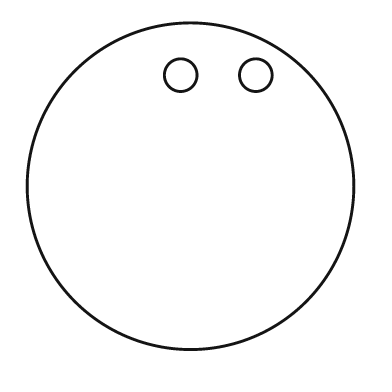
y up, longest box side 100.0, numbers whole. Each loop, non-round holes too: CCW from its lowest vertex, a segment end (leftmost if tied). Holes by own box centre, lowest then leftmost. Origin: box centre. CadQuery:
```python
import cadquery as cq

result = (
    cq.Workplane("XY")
    .moveTo(0.0, 0.0)
    .circle(50.0)
    .moveTo(-3.0, 34.0)
    .circle(5.0)
    .moveTo(20.0, 34.0)
    .circle(5.0)
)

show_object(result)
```